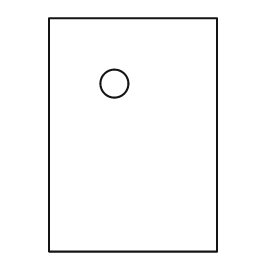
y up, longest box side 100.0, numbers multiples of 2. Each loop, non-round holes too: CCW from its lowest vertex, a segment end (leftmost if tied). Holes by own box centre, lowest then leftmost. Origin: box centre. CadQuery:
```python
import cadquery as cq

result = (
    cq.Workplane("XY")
    .moveTo(-36.0, -50.0)
    .lineTo(36.0, -50.0)
    .lineTo(36.0, 50.0)
    .lineTo(-36.0, 50.0)
    .close()
    .moveTo(-8.0, 22.0)
    .circle(6.0)
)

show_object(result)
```